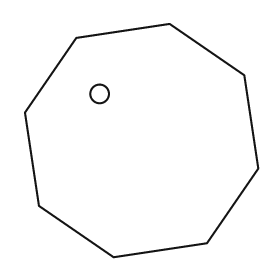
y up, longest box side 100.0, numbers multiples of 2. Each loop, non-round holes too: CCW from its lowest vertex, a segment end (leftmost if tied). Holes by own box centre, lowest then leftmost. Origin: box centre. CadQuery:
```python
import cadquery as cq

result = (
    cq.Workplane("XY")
    .moveTo(-12.0, -50.0)
    .lineTo(28.0, -44.0)
    .lineTo(50.0, -12.0)
    .lineTo(44.0, 28.0)
    .lineTo(12.0, 50.0)
    .lineTo(-28.0, 44.0)
    .lineTo(-50.0, 12.0)
    .lineTo(-44.0, -28.0)
    .close()
    .moveTo(-18.0, 20.0)
    .circle(4.0)
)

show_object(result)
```